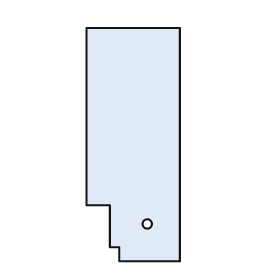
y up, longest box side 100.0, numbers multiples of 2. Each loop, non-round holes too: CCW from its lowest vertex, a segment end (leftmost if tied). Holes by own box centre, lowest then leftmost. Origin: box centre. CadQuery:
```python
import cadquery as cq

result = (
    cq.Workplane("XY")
    .moveTo(-6.0, -50.0)
    .lineTo(20.0, -50.0)
    .lineTo(20.0, 50.0)
    .lineTo(-20.0, 50.0)
    .lineTo(-20.0, -26.0)
    .lineTo(-10.0, -26.0)
    .lineTo(-10.0, -44.0)
    .lineTo(-6.0, -44.0)
    .close()
    .moveTo(6.0, -34.0)
    .circle(2.0)
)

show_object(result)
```